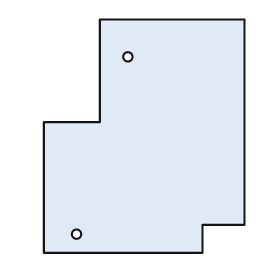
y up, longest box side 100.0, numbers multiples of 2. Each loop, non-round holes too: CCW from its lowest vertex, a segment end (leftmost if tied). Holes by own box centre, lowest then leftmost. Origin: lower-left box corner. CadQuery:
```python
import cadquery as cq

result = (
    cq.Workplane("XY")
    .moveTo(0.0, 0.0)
    .lineTo(68.0, 0.0)
    .lineTo(68.0, 12.0)
    .lineTo(86.0, 12.0)
    .lineTo(86.0, 100.0)
    .lineTo(24.0, 100.0)
    .lineTo(24.0, 56.0)
    .lineTo(0.0, 56.0)
    .close()
    .moveTo(14.0, 8.0)
    .circle(2.0)
    .moveTo(36.0, 84.0)
    .circle(2.0)
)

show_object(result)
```